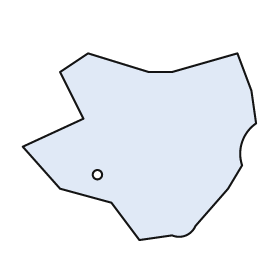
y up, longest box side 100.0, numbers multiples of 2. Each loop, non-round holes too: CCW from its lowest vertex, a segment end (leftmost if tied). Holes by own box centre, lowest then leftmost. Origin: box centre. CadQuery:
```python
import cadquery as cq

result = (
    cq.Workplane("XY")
    .moveTo(0.0, -40.0)
    .lineTo(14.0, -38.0)
    .threePointArc((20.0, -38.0), (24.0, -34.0))
    .lineTo(38.0, -18.0)
    .lineTo(44.0, -8.0)
    .threePointArc((44.0, 2.0), (50.0, 10.0))
    .lineTo(48.0, 24.0)
    .lineTo(42.0, 40.0)
    .lineTo(14.0, 32.0)
    .lineTo(4.0, 32.0)
    .lineTo(-22.0, 40.0)
    .lineTo(-34.0, 32.0)
    .lineTo(-24.0, 12.0)
    .lineTo(-50.0, 0.0)
    .lineTo(-34.0, -18.0)
    .lineTo(-12.0, -24.0)
    .close()
    .moveTo(-18.0, -12.0)
    .circle(2.0)
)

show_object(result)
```